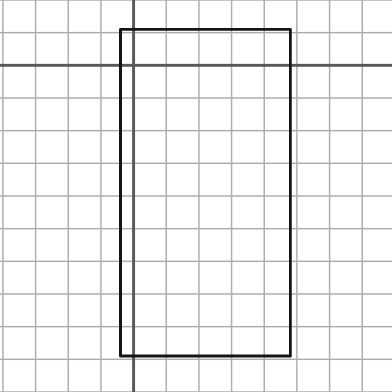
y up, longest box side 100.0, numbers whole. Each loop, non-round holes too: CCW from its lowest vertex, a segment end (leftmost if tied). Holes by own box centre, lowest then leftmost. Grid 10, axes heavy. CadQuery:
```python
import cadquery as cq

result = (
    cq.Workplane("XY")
    .moveTo(-4.0, -89.0)
    .lineTo(48.0, -89.0)
    .lineTo(48.0, 11.0)
    .lineTo(-4.0, 11.0)
    .close()
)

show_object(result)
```